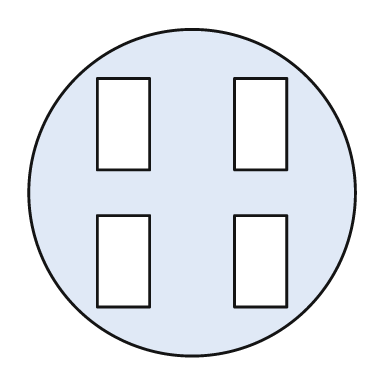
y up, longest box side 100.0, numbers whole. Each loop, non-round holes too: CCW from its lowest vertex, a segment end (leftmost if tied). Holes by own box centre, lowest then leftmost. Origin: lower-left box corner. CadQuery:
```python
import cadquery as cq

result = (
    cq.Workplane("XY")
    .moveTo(50.0, 50.0)
    .circle(50.0)
    .moveTo(21.0, 15.0)
    .lineTo(37.0, 15.0)
    .lineTo(37.0, 43.0)
    .lineTo(21.0, 43.0)
    .close()
    .moveTo(63.0, 15.0)
    .lineTo(79.0, 15.0)
    .lineTo(79.0, 43.0)
    .lineTo(63.0, 43.0)
    .close()
    .moveTo(21.0, 57.0)
    .lineTo(37.0, 57.0)
    .lineTo(37.0, 85.0)
    .lineTo(21.0, 85.0)
    .close()
    .moveTo(63.0, 57.0)
    .lineTo(79.0, 57.0)
    .lineTo(79.0, 85.0)
    .lineTo(63.0, 85.0)
    .close()
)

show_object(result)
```